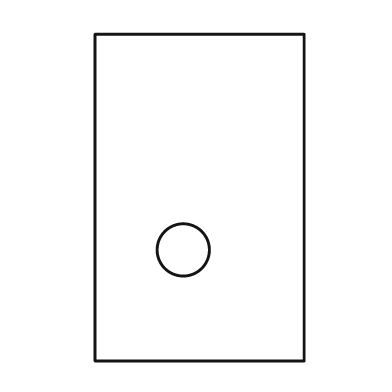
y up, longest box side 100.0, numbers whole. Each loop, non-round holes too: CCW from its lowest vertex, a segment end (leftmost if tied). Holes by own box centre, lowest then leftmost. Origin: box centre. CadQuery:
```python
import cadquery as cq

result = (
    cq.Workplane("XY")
    .moveTo(-32.0, -50.0)
    .lineTo(32.0, -50.0)
    .lineTo(32.0, 50.0)
    .lineTo(-32.0, 50.0)
    .close()
    .moveTo(-5.0, -16.0)
    .circle(8.0)
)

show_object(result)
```